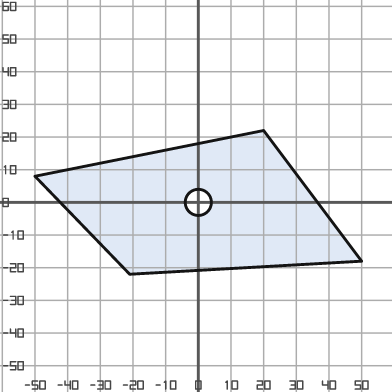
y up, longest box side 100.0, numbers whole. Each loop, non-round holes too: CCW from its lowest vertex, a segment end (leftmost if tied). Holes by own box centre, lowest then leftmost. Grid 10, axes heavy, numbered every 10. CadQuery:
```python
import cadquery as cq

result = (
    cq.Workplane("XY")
    .moveTo(-21.0, -22.0)
    .lineTo(50.0, -18.0)
    .lineTo(20.0, 22.0)
    .lineTo(-50.0, 8.0)
    .close()
    .moveTo(0.0, 0.0)
    .circle(4.0)
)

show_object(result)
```